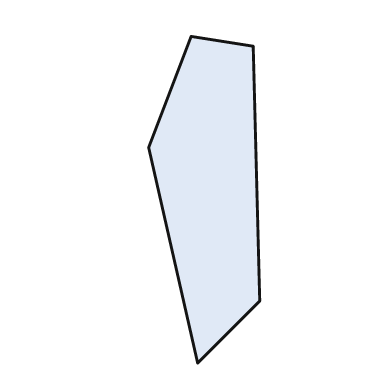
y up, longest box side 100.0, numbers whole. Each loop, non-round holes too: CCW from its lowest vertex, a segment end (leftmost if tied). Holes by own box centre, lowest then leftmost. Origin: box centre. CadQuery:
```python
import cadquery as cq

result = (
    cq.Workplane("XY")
    .moveTo(-2.0, -50.0)
    .lineTo(17.0, -31.0)
    .lineTo(15.0, 47.0)
    .lineTo(-4.0, 50.0)
    .lineTo(-17.0, 16.0)
    .close()
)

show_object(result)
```